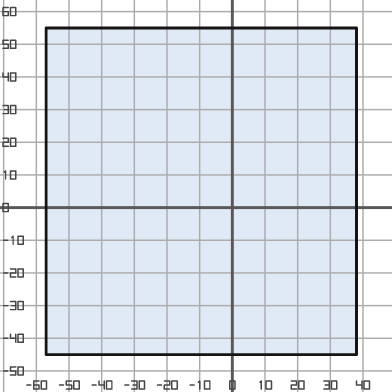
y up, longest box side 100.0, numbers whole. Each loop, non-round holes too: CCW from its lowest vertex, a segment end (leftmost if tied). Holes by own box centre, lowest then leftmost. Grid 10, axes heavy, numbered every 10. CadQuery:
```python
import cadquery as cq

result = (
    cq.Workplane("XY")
    .moveTo(-57.0, -45.0)
    .lineTo(38.0, -45.0)
    .lineTo(38.0, 55.0)
    .lineTo(-57.0, 55.0)
    .close()
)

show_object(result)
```